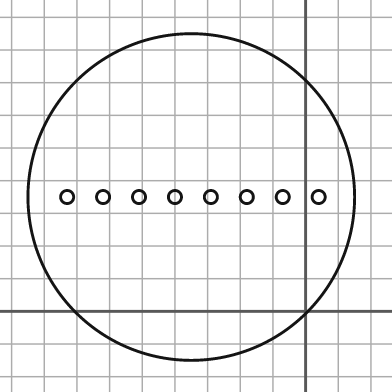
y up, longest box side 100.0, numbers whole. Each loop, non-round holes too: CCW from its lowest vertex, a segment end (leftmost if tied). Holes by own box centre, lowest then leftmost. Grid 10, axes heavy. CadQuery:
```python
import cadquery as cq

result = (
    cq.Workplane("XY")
    .moveTo(-35.0, 35.0)
    .circle(50.0)
    .moveTo(-73.0, 35.0)
    .circle(2.0)
    .moveTo(-62.0, 35.0)
    .circle(2.0)
    .moveTo(-51.0, 35.0)
    .circle(2.0)
    .moveTo(-40.0, 35.0)
    .circle(2.0)
    .moveTo(-29.0, 35.0)
    .circle(2.0)
    .moveTo(-18.0, 35.0)
    .circle(2.0)
    .moveTo(-7.0, 35.0)
    .circle(2.0)
    .moveTo(4.0, 35.0)
    .circle(2.0)
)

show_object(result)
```